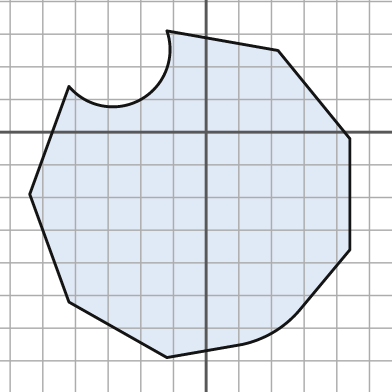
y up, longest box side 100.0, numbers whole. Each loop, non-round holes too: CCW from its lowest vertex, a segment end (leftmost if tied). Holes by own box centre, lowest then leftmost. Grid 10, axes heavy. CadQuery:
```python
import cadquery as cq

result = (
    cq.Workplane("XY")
    .moveTo(-12.0, -69.0)
    .lineTo(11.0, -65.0)
    .threePointArc((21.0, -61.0), (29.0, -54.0))
    .lineTo(44.0, -36.0)
    .lineTo(44.0, -2.0)
    .lineTo(22.0, 25.0)
    .lineTo(-12.0, 31.0)
    .threePointArc((-20.0, 10.0), (-42.0, 14.0))
    .lineTo(-54.0, -19.0)
    .lineTo(-42.0, -52.0)
    .close()
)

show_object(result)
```